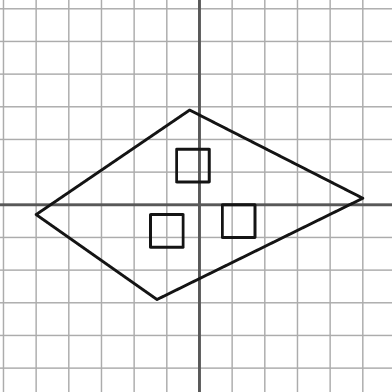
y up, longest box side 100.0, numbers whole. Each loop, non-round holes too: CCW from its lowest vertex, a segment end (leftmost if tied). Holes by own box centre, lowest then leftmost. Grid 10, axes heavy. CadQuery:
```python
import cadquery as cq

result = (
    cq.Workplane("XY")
    .moveTo(-13.0, -29.0)
    .lineTo(50.0, 2.0)
    .lineTo(-3.0, 29.0)
    .lineTo(-50.0, -3.0)
    .close()
    .moveTo(-15.0, -13.0)
    .lineTo(-5.0, -13.0)
    .lineTo(-5.0, -3.0)
    .lineTo(-15.0, -3.0)
    .close()
    .moveTo(7.0, -10.0)
    .lineTo(17.0, -10.0)
    .lineTo(17.0, 0.0)
    .lineTo(7.0, 0.0)
    .close()
    .moveTo(-7.0, 7.0)
    .lineTo(3.0, 7.0)
    .lineTo(3.0, 17.0)
    .lineTo(-7.0, 17.0)
    .close()
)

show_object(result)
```